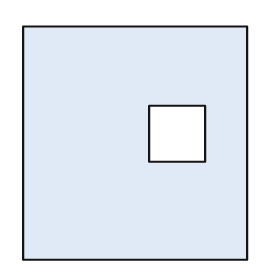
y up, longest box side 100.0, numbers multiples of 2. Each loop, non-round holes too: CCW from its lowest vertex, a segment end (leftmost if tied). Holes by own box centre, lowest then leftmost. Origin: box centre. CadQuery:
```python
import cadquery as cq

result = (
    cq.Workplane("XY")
    .moveTo(-48.0, -50.0)
    .lineTo(48.0, -50.0)
    .lineTo(48.0, 50.0)
    .lineTo(-48.0, 50.0)
    .close()
    .moveTo(6.0, -8.0)
    .lineTo(30.0, -8.0)
    .lineTo(30.0, 16.0)
    .lineTo(6.0, 16.0)
    .close()
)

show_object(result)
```